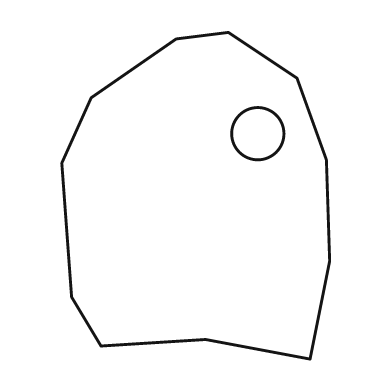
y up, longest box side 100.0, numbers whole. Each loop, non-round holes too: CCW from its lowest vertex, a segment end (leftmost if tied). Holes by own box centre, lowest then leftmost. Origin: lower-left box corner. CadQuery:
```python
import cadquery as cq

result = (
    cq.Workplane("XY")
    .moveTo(76.0, 0.0)
    .lineTo(82.0, 30.0)
    .lineTo(81.0, 61.0)
    .lineTo(72.0, 86.0)
    .lineTo(51.0, 100.0)
    .lineTo(35.0, 98.0)
    .lineTo(9.0, 80.0)
    .lineTo(0.0, 60.0)
    .lineTo(3.0, 19.0)
    .lineTo(12.0, 4.0)
    .lineTo(44.0, 6.0)
    .close()
    .moveTo(60.0, 69.0)
    .circle(8.0)
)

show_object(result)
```